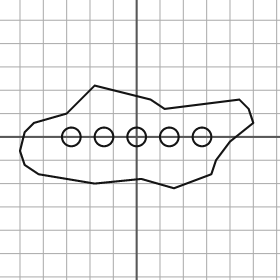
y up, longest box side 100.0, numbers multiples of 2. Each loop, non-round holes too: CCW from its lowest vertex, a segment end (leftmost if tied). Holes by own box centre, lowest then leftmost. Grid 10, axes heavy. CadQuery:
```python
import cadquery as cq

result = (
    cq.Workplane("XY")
    .moveTo(16.0, -22.0)
    .lineTo(32.0, -16.0)
    .lineTo(34.0, -10.0)
    .lineTo(40.0, -2.0)
    .lineTo(50.0, 6.0)
    .lineTo(48.0, 12.0)
    .lineTo(44.0, 16.0)
    .lineTo(12.0, 12.0)
    .lineTo(6.0, 16.0)
    .lineTo(-18.0, 22.0)
    .lineTo(-30.0, 10.0)
    .lineTo(-44.0, 6.0)
    .lineTo(-48.0, 2.0)
    .lineTo(-50.0, -6.0)
    .lineTo(-48.0, -12.0)
    .lineTo(-42.0, -16.0)
    .lineTo(-18.0, -20.0)
    .lineTo(2.0, -18.0)
    .close()
    .moveTo(-28.0, 0.0)
    .circle(4.0)
    .moveTo(-14.0, 0.0)
    .circle(4.0)
    .moveTo(0.0, 0.0)
    .circle(4.0)
    .moveTo(14.0, 0.0)
    .circle(4.0)
    .moveTo(28.0, 0.0)
    .circle(4.0)
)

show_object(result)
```